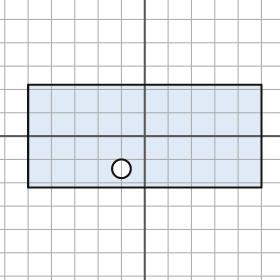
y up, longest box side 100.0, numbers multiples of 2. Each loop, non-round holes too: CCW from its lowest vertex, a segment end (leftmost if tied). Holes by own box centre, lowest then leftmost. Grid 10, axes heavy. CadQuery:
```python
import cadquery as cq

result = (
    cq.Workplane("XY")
    .moveTo(-50.0, -22.0)
    .lineTo(50.0, -22.0)
    .lineTo(50.0, 22.0)
    .lineTo(-50.0, 22.0)
    .close()
    .moveTo(-10.0, -14.0)
    .circle(4.0)
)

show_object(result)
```